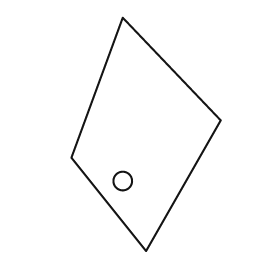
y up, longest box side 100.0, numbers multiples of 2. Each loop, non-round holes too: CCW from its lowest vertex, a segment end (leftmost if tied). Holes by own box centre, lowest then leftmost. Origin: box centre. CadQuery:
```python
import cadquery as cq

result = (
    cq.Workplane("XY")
    .moveTo(0.0, -50.0)
    .lineTo(32.0, 6.0)
    .lineTo(-10.0, 50.0)
    .lineTo(-32.0, -10.0)
    .close()
    .moveTo(-10.0, -20.0)
    .circle(4.0)
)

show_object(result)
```